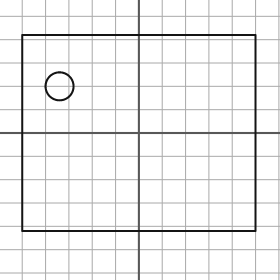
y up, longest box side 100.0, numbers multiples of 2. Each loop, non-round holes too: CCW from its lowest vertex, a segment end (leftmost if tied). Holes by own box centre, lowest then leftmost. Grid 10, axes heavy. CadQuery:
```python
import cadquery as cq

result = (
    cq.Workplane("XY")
    .moveTo(-50.0, -42.0)
    .lineTo(50.0, -42.0)
    .lineTo(50.0, 42.0)
    .lineTo(-50.0, 42.0)
    .close()
    .moveTo(-34.0, 20.0)
    .circle(6.0)
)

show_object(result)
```